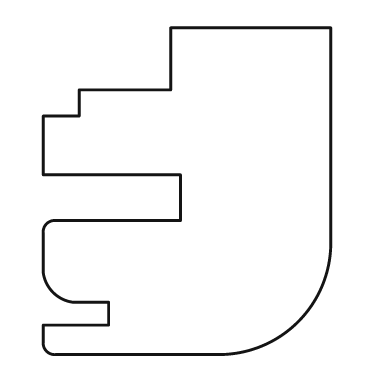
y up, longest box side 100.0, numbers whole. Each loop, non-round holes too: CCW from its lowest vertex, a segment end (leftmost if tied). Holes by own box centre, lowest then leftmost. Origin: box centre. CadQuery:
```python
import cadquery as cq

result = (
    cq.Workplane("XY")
    .moveTo(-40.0, -50.0)
    .lineTo(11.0, -50.0)
    .threePointArc((34.0, -40.0), (44.0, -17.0))
    .lineTo(44.0, 50.0)
    .lineTo(-5.0, 50.0)
    .lineTo(-5.0, 31.0)
    .lineTo(-33.0, 31.0)
    .lineTo(-33.0, 23.0)
    .lineTo(-44.0, 23.0)
    .lineTo(-44.0, 5.0)
    .lineTo(-2.0, 5.0)
    .lineTo(-2.0, -9.0)
    .lineTo(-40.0, -9.0)
    .threePointArc((-43.0, -10.0), (-44.0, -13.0))
    .lineTo(-44.0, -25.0)
    .threePointArc((-41.0, -31.0), (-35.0, -34.0))
    .lineTo(-24.0, -34.0)
    .lineTo(-24.0, -41.0)
    .lineTo(-44.0, -41.0)
    .lineTo(-44.0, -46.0)
    .threePointArc((-43.0, -49.0), (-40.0, -50.0))
    .close()
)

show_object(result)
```